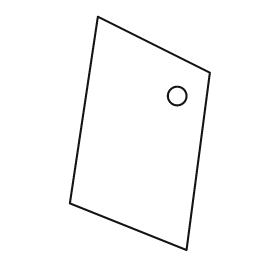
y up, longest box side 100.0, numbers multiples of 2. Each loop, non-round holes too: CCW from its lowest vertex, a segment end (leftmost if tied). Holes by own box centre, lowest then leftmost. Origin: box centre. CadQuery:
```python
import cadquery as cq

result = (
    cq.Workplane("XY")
    .moveTo(20.0, -50.0)
    .lineTo(30.0, 26.0)
    .lineTo(-18.0, 50.0)
    .lineTo(-30.0, -30.0)
    .close()
    .moveTo(16.0, 16.0)
    .circle(4.0)
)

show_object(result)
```